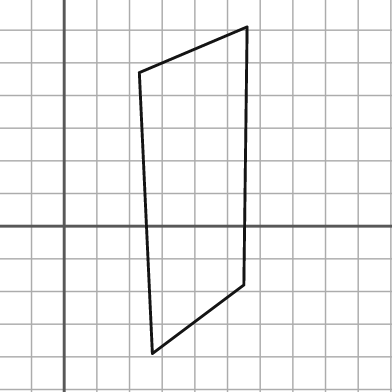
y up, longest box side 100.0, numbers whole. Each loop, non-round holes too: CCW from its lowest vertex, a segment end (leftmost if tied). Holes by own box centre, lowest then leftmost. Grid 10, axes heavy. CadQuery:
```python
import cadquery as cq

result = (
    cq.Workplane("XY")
    .moveTo(27.0, -39.0)
    .lineTo(55.0, -18.0)
    .lineTo(56.0, 61.0)
    .lineTo(23.0, 47.0)
    .close()
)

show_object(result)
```